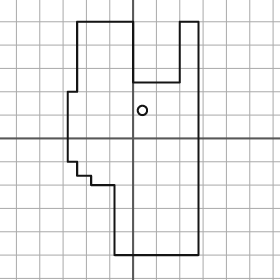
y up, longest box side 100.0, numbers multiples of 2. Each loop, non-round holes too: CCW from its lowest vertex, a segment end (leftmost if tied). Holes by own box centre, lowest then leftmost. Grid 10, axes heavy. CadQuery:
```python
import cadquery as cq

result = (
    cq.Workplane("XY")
    .moveTo(-8.0, -50.0)
    .lineTo(28.0, -50.0)
    .lineTo(28.0, 50.0)
    .lineTo(20.0, 50.0)
    .lineTo(20.0, 24.0)
    .lineTo(0.0, 24.0)
    .lineTo(0.0, 50.0)
    .lineTo(-24.0, 50.0)
    .lineTo(-24.0, 20.0)
    .lineTo(-28.0, 20.0)
    .lineTo(-28.0, -10.0)
    .lineTo(-24.0, -10.0)
    .lineTo(-24.0, -16.0)
    .lineTo(-18.0, -16.0)
    .lineTo(-18.0, -20.0)
    .lineTo(-8.0, -20.0)
    .close()
    .moveTo(4.0, 12.0)
    .circle(2.0)
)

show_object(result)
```